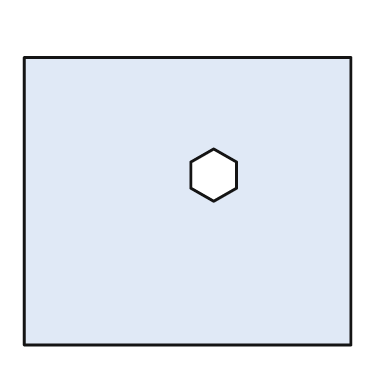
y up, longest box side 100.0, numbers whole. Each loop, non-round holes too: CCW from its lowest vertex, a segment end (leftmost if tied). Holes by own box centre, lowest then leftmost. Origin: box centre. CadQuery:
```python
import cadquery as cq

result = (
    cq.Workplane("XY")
    .moveTo(-50.0, -44.0)
    .lineTo(50.0, -44.0)
    .lineTo(50.0, 44.0)
    .lineTo(-50.0, 44.0)
    .close()
    .moveTo(8.0, 0.0)
    .lineTo(15.0, 4.0)
    .lineTo(15.0, 12.0)
    .lineTo(8.0, 16.0)
    .lineTo(1.0, 12.0)
    .lineTo(1.0, 4.0)
    .close()
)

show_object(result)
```